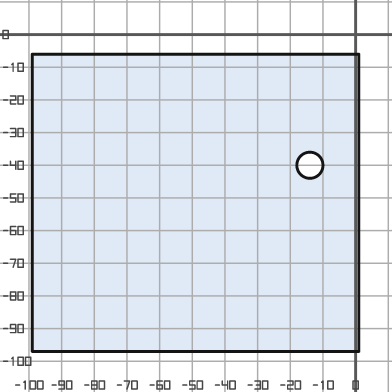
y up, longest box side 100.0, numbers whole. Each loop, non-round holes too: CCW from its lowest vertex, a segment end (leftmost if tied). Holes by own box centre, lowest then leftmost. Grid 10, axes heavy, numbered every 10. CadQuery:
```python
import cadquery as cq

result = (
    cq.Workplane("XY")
    .moveTo(-99.0, -97.0)
    .lineTo(1.0, -97.0)
    .lineTo(1.0, -6.0)
    .lineTo(-99.0, -6.0)
    .close()
    .moveTo(-14.0, -40.0)
    .circle(4.0)
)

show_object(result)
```